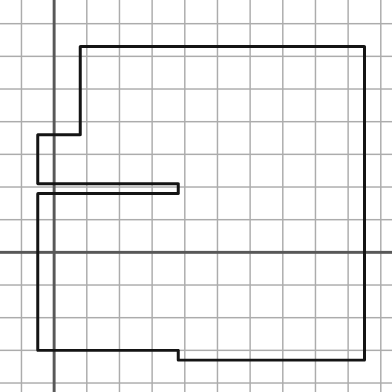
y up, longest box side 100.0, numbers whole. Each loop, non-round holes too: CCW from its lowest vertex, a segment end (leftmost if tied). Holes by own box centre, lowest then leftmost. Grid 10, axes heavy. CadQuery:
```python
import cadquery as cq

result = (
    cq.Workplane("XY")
    .moveTo(38.0, -33.0)
    .lineTo(95.0, -33.0)
    .lineTo(95.0, 63.0)
    .lineTo(8.0, 63.0)
    .lineTo(8.0, 36.0)
    .lineTo(-5.0, 36.0)
    .lineTo(-5.0, 21.0)
    .lineTo(38.0, 21.0)
    .lineTo(38.0, 18.0)
    .lineTo(-5.0, 18.0)
    .lineTo(-5.0, -30.0)
    .lineTo(38.0, -30.0)
    .close()
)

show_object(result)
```